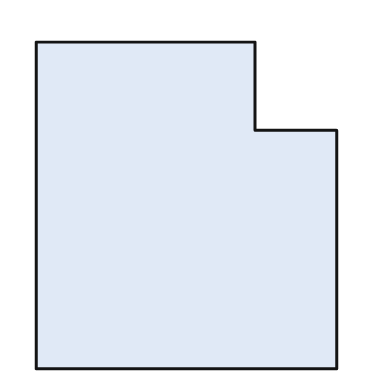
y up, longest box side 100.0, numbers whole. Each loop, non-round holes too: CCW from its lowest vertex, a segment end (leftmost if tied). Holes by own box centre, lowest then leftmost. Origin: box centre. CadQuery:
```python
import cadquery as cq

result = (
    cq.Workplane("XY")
    .moveTo(-46.0, -50.0)
    .lineTo(46.0, -50.0)
    .lineTo(46.0, 23.0)
    .lineTo(21.0, 23.0)
    .lineTo(21.0, 50.0)
    .lineTo(-46.0, 50.0)
    .close()
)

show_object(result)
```